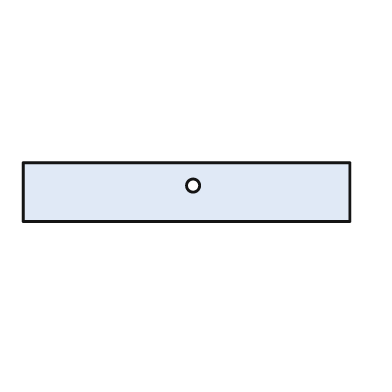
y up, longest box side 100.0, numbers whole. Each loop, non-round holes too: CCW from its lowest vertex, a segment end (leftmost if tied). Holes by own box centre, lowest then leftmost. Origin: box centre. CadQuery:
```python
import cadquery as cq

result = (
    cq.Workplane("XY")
    .moveTo(-50.0, -9.0)
    .lineTo(50.0, -9.0)
    .lineTo(50.0, 9.0)
    .lineTo(-50.0, 9.0)
    .close()
    .moveTo(2.0, 2.0)
    .circle(2.0)
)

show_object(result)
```